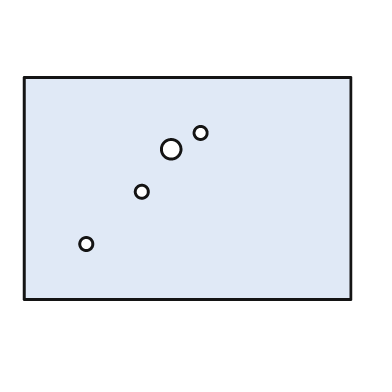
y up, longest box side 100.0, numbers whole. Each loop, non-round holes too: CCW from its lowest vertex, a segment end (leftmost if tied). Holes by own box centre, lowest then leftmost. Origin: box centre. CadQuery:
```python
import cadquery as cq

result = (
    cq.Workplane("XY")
    .moveTo(-50.0, -34.0)
    .lineTo(50.0, -34.0)
    .lineTo(50.0, 34.0)
    .lineTo(-50.0, 34.0)
    .close()
    .moveTo(-31.0, -17.0)
    .circle(2.0)
    .moveTo(-14.0, -1.0)
    .circle(2.0)
    .moveTo(-5.0, 12.0)
    .circle(3.0)
    .moveTo(4.0, 17.0)
    .circle(2.0)
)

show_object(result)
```